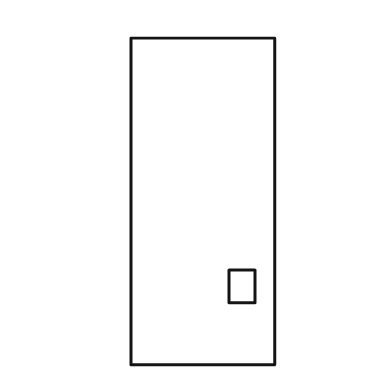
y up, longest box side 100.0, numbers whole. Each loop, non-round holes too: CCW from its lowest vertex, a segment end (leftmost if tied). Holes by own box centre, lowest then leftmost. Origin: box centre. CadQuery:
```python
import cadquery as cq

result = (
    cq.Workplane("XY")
    .moveTo(-22.0, -50.0)
    .lineTo(22.0, -50.0)
    .lineTo(22.0, 50.0)
    .lineTo(-22.0, 50.0)
    .close()
    .moveTo(8.0, -31.0)
    .lineTo(16.0, -31.0)
    .lineTo(16.0, -21.0)
    .lineTo(8.0, -21.0)
    .close()
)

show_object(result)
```